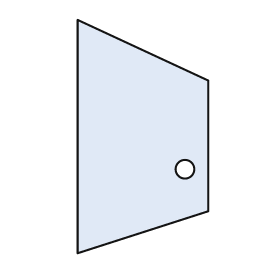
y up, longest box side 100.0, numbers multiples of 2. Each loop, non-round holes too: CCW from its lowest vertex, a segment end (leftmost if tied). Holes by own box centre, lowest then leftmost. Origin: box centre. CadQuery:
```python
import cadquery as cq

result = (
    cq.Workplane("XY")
    .moveTo(-28.0, -50.0)
    .lineTo(28.0, -32.0)
    .lineTo(28.0, 24.0)
    .lineTo(-28.0, 50.0)
    .close()
    .moveTo(18.0, -14.0)
    .circle(4.0)
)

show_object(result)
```